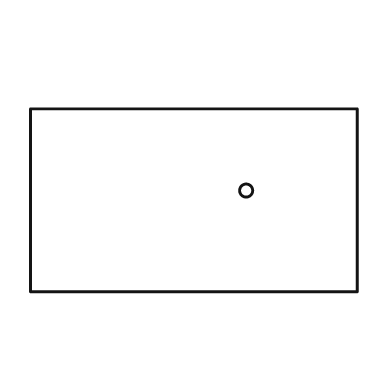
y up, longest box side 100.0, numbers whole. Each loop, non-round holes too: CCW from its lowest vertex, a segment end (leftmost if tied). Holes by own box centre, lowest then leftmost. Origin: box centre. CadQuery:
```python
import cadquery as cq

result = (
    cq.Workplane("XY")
    .moveTo(-50.0, -28.0)
    .lineTo(50.0, -28.0)
    .lineTo(50.0, 28.0)
    .lineTo(-50.0, 28.0)
    .close()
    .moveTo(16.0, 3.0)
    .circle(2.0)
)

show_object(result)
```